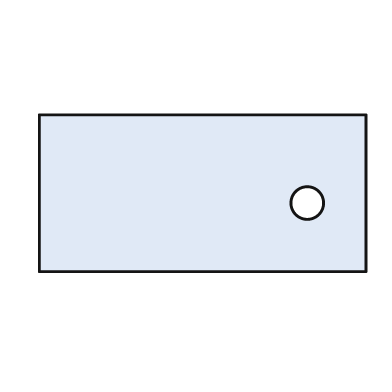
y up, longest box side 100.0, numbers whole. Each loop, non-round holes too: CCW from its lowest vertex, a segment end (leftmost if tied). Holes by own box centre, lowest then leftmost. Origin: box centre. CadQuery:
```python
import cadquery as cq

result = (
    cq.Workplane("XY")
    .moveTo(-50.0, -24.0)
    .lineTo(50.0, -24.0)
    .lineTo(50.0, 24.0)
    .lineTo(-50.0, 24.0)
    .close()
    .moveTo(32.0, -3.0)
    .circle(5.0)
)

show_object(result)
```